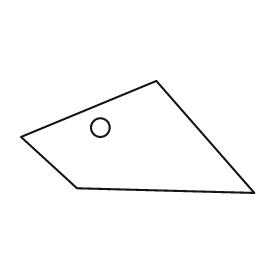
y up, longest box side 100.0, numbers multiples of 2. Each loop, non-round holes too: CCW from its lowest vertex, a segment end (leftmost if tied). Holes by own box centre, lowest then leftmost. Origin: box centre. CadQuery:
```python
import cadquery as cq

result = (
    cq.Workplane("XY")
    .moveTo(50.0, -24.0)
    .lineTo(8.0, 24.0)
    .lineTo(-50.0, 0.0)
    .lineTo(-26.0, -22.0)
    .close()
    .moveTo(-16.0, 4.0)
    .circle(4.0)
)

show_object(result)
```